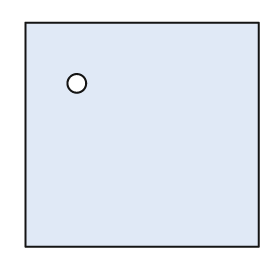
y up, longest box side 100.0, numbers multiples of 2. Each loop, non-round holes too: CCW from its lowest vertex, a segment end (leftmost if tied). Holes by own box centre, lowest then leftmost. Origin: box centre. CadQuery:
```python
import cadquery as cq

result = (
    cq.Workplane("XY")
    .moveTo(-50.0, -48.0)
    .lineTo(50.0, -48.0)
    .lineTo(50.0, 48.0)
    .lineTo(-50.0, 48.0)
    .close()
    .moveTo(-28.0, 22.0)
    .circle(4.0)
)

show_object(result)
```